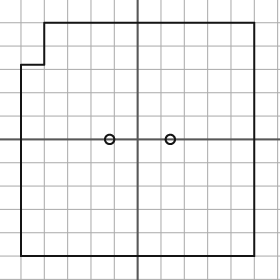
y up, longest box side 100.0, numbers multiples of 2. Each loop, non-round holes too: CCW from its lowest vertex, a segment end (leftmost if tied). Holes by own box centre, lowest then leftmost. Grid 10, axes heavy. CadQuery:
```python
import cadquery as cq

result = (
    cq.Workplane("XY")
    .moveTo(-50.0, -50.0)
    .lineTo(50.0, -50.0)
    .lineTo(50.0, 50.0)
    .lineTo(-40.0, 50.0)
    .lineTo(-40.0, 32.0)
    .lineTo(-50.0, 32.0)
    .close()
    .moveTo(-12.0, 0.0)
    .circle(2.0)
    .moveTo(14.0, 0.0)
    .circle(2.0)
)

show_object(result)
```